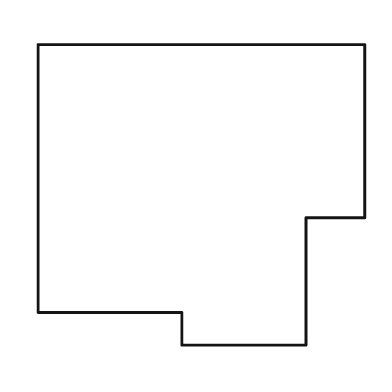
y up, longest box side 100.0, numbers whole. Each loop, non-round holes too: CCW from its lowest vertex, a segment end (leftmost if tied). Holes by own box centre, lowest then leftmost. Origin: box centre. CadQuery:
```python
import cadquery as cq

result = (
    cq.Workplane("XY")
    .moveTo(-6.0, -46.0)
    .lineTo(32.0, -46.0)
    .lineTo(32.0, -7.0)
    .lineTo(50.0, -7.0)
    .lineTo(50.0, 46.0)
    .lineTo(-50.0, 46.0)
    .lineTo(-50.0, -36.0)
    .lineTo(-6.0, -36.0)
    .close()
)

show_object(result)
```